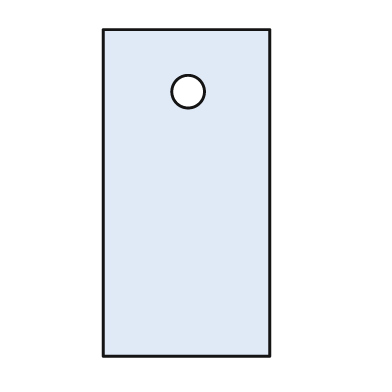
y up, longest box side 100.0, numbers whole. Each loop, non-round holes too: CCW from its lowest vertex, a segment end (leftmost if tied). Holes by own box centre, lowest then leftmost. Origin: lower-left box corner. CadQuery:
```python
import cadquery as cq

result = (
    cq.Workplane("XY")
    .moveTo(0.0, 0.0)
    .lineTo(51.0, 0.0)
    .lineTo(51.0, 100.0)
    .lineTo(0.0, 100.0)
    .close()
    .moveTo(26.0, 81.0)
    .circle(5.0)
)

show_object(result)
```